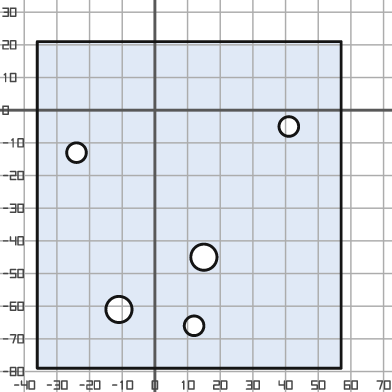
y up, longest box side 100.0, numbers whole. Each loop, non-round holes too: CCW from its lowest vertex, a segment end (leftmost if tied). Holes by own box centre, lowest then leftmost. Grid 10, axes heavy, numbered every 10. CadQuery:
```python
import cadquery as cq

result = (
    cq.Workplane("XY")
    .moveTo(-36.0, -79.0)
    .lineTo(57.0, -79.0)
    .lineTo(57.0, 21.0)
    .lineTo(-36.0, 21.0)
    .close()
    .moveTo(12.0, -66.0)
    .circle(3.0)
    .moveTo(-11.0, -61.0)
    .circle(4.0)
    .moveTo(15.0, -45.0)
    .circle(4.0)
    .moveTo(-24.0, -13.0)
    .circle(3.0)
    .moveTo(41.0, -5.0)
    .circle(3.0)
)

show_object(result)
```